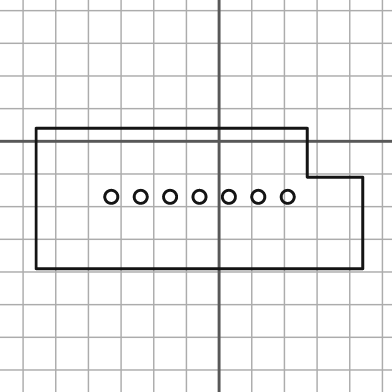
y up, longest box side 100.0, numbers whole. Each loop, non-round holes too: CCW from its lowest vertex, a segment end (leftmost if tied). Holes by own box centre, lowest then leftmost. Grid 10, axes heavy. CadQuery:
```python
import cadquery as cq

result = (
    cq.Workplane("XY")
    .moveTo(-56.0, -39.0)
    .lineTo(44.0, -39.0)
    .lineTo(44.0, -11.0)
    .lineTo(27.0, -11.0)
    .lineTo(27.0, 4.0)
    .lineTo(-56.0, 4.0)
    .close()
    .moveTo(-33.0, -17.0)
    .circle(2.0)
    .moveTo(-24.0, -17.0)
    .circle(2.0)
    .moveTo(-15.0, -17.0)
    .circle(2.0)
    .moveTo(-6.0, -17.0)
    .circle(2.0)
    .moveTo(3.0, -17.0)
    .circle(2.0)
    .moveTo(12.0, -17.0)
    .circle(2.0)
    .moveTo(21.0, -17.0)
    .circle(2.0)
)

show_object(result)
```